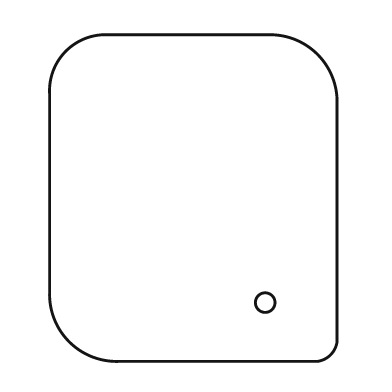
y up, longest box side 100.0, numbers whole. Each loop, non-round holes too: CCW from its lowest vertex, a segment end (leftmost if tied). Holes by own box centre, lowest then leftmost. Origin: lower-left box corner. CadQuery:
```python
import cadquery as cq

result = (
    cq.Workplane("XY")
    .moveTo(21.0, 0.0)
    .lineTo(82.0, 0.0)
    .threePointArc((86.0, 2.0), (88.0, 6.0))
    .lineTo(88.0, 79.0)
    .threePointArc((82.0, 94.0), (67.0, 100.0))
    .lineTo(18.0, 100.0)
    .threePointArc((5.0, 95.0), (0.0, 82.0))
    .lineTo(0.0, 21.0)
    .threePointArc((6.0, 6.0), (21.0, 0.0))
    .close()
    .moveTo(66.0, 18.0)
    .circle(3.0)
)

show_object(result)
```